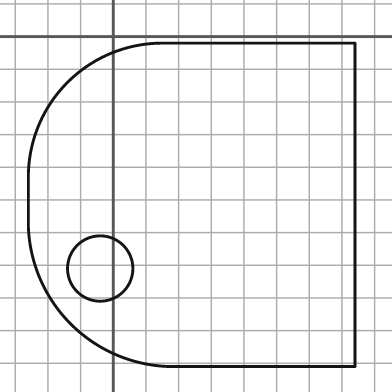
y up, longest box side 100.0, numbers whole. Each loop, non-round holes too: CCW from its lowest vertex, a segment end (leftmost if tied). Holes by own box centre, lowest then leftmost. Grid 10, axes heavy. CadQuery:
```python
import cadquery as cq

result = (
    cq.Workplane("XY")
    .moveTo(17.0, -101.0)
    .lineTo(74.0, -101.0)
    .lineTo(74.0, -2.0)
    .lineTo(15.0, -2.0)
    .threePointArc((-14.0, -14.0), (-26.0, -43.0))
    .lineTo(-26.0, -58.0)
    .threePointArc((-13.0, -88.0), (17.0, -101.0))
    .close()
    .moveTo(-4.0, -71.0)
    .circle(10.0)
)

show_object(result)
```